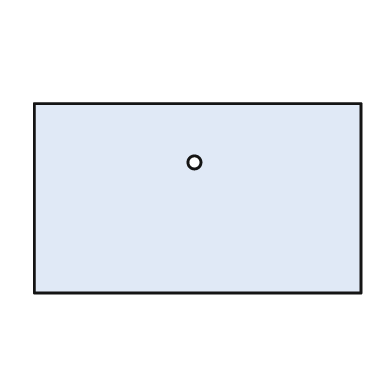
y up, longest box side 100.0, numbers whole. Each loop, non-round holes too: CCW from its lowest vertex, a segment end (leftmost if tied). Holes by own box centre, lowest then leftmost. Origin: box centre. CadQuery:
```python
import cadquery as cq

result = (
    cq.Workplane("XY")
    .moveTo(-50.0, -29.0)
    .lineTo(50.0, -29.0)
    .lineTo(50.0, 29.0)
    .lineTo(-50.0, 29.0)
    .close()
    .moveTo(-1.0, 11.0)
    .circle(2.0)
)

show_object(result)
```